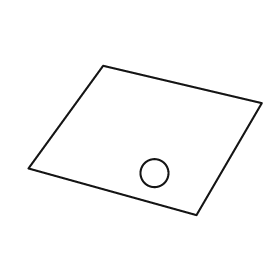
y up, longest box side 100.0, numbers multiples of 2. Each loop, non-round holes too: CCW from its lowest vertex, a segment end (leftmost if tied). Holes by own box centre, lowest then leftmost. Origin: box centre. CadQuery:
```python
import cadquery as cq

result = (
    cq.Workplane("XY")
    .moveTo(22.0, -32.0)
    .lineTo(50.0, 16.0)
    .lineTo(-18.0, 32.0)
    .lineTo(-50.0, -12.0)
    .close()
    .moveTo(4.0, -14.0)
    .circle(6.0)
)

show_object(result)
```